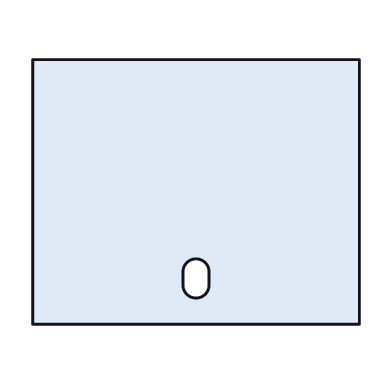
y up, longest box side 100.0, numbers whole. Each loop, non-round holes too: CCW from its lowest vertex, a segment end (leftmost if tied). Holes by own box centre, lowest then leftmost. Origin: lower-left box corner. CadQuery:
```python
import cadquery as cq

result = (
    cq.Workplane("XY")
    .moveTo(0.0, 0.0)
    .lineTo(100.0, 0.0)
    .lineTo(100.0, 81.0)
    .lineTo(0.0, 81.0)
    .close()
    .moveTo(46.0, 12.0)
    .threePointArc((50.0, 8.0), (54.0, 12.0))
    .lineTo(54.0, 16.0)
    .threePointArc((50.0, 20.0), (46.0, 16.0))
    .close()
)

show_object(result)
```